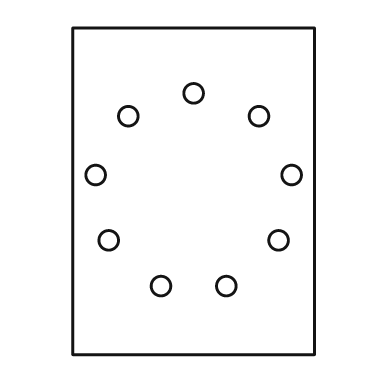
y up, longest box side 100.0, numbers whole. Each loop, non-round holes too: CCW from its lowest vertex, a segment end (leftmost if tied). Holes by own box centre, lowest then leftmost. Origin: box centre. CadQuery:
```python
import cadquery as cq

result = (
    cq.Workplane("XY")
    .moveTo(-37.0, -50.0)
    .lineTo(37.0, -50.0)
    .lineTo(37.0, 50.0)
    .lineTo(-37.0, 50.0)
    .close()
    .moveTo(-10.0, -29.0)
    .circle(3.0)
    .moveTo(10.0, -29.0)
    .circle(3.0)
    .moveTo(-26.0, -15.0)
    .circle(3.0)
    .moveTo(26.0, -15.0)
    .circle(3.0)
    .moveTo(-30.0, 5.0)
    .circle(3.0)
    .moveTo(30.0, 5.0)
    .circle(3.0)
    .moveTo(-20.0, 23.0)
    .circle(3.0)
    .moveTo(20.0, 23.0)
    .circle(3.0)
    .moveTo(0.0, 30.0)
    .circle(3.0)
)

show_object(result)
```